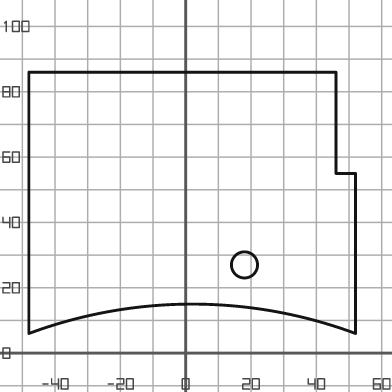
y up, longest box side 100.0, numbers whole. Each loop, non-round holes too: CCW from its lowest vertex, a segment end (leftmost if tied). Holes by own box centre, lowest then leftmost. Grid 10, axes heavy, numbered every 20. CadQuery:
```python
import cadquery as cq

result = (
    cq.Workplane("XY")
    .moveTo(-48.0, 6.0)
    .threePointArc((2.0, 15.0), (52.0, 6.0))
    .lineTo(52.0, 55.0)
    .lineTo(46.0, 55.0)
    .lineTo(46.0, 86.0)
    .lineTo(-48.0, 86.0)
    .close()
    .moveTo(18.0, 27.0)
    .circle(4.0)
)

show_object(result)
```